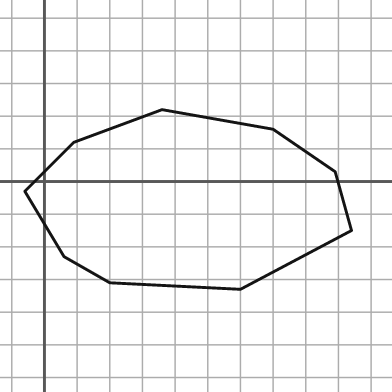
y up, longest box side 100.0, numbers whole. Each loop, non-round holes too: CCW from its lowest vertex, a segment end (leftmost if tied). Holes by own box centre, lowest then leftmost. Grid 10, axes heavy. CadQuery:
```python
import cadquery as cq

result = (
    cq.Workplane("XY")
    .moveTo(60.0, -33.0)
    .lineTo(94.0, -15.0)
    .lineTo(89.0, 3.0)
    .lineTo(70.0, 16.0)
    .lineTo(36.0, 22.0)
    .lineTo(9.0, 12.0)
    .lineTo(-6.0, -3.0)
    .lineTo(6.0, -23.0)
    .lineTo(20.0, -31.0)
    .close()
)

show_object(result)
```